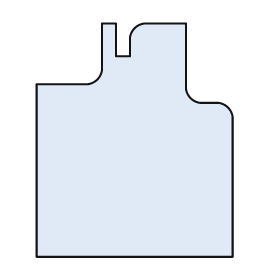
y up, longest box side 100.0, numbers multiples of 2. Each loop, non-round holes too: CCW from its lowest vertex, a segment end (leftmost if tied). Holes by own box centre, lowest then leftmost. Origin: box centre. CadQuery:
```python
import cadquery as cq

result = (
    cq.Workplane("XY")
    .moveTo(-42.0, -50.0)
    .lineTo(42.0, -50.0)
    .lineTo(42.0, 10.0)
    .threePointArc((40.0, 14.0), (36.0, 16.0))
    .lineTo(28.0, 16.0)
    .threePointArc((24.0, 18.0), (22.0, 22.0))
    .lineTo(22.0, 50.0)
    .lineTo(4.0, 50.0)
    .threePointArc((0.0, 48.0), (-2.0, 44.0))
    .lineTo(-2.0, 36.0)
    .lineTo(-8.0, 36.0)
    .lineTo(-8.0, 50.0)
    .lineTo(-14.0, 50.0)
    .lineTo(-14.0, 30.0)
    .threePointArc((-16.0, 26.0), (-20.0, 24.0))
    .lineTo(-42.0, 24.0)
    .close()
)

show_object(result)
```